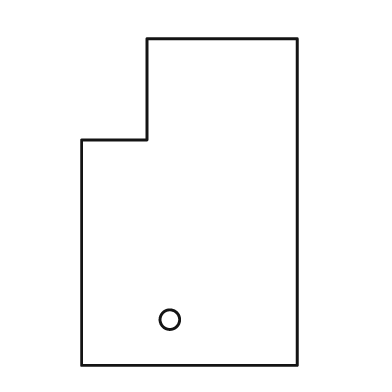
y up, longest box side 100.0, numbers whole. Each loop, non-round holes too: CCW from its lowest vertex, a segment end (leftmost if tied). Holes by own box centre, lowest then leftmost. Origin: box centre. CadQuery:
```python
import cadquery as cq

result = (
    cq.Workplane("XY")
    .moveTo(-33.0, -50.0)
    .lineTo(33.0, -50.0)
    .lineTo(33.0, 50.0)
    .lineTo(-13.0, 50.0)
    .lineTo(-13.0, 19.0)
    .lineTo(-33.0, 19.0)
    .close()
    .moveTo(-6.0, -36.0)
    .circle(3.0)
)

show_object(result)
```